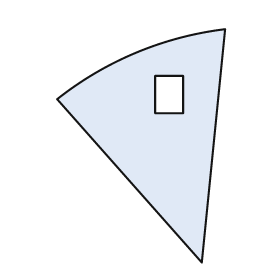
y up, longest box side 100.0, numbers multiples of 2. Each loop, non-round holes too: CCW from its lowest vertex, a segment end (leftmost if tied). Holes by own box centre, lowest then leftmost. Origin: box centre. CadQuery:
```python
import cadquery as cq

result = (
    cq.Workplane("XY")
    .moveTo(26.0, -50.0)
    .lineTo(36.0, 50.0)
    .threePointArc((-2.0, 40.0), (-36.0, 20.0))
    .close()
    .moveTo(6.0, 14.0)
    .lineTo(18.0, 14.0)
    .lineTo(18.0, 30.0)
    .lineTo(6.0, 30.0)
    .close()
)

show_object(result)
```